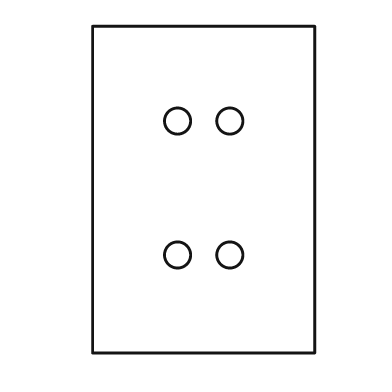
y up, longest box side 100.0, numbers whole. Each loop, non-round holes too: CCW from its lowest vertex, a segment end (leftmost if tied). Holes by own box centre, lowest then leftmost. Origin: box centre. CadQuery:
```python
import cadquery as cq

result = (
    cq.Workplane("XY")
    .moveTo(-34.0, -50.0)
    .lineTo(34.0, -50.0)
    .lineTo(34.0, 50.0)
    .lineTo(-34.0, 50.0)
    .close()
    .moveTo(-8.0, -20.0)
    .circle(4.0)
    .moveTo(8.0, -20.0)
    .circle(4.0)
    .moveTo(-8.0, 21.0)
    .circle(4.0)
    .moveTo(8.0, 21.0)
    .circle(4.0)
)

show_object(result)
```